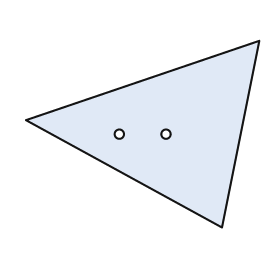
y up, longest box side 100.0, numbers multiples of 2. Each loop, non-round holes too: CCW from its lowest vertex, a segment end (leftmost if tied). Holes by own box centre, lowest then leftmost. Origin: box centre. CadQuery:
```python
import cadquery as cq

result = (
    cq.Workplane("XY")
    .moveTo(34.0, -40.0)
    .lineTo(50.0, 40.0)
    .lineTo(-50.0, 6.0)
    .close()
    .moveTo(-10.0, 0.0)
    .circle(2.0)
    .moveTo(10.0, 0.0)
    .circle(2.0)
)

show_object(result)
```